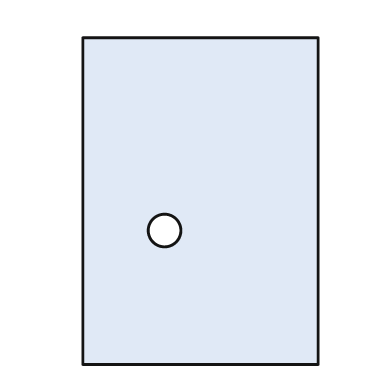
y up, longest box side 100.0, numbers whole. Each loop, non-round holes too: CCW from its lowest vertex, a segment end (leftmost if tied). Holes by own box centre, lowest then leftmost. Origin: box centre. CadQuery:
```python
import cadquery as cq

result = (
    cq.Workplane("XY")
    .moveTo(-36.0, -50.0)
    .lineTo(36.0, -50.0)
    .lineTo(36.0, 50.0)
    .lineTo(-36.0, 50.0)
    .close()
    .moveTo(-11.0, -9.0)
    .circle(5.0)
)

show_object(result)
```